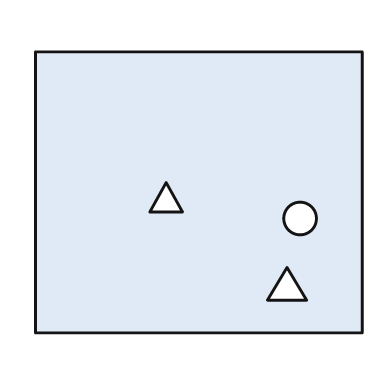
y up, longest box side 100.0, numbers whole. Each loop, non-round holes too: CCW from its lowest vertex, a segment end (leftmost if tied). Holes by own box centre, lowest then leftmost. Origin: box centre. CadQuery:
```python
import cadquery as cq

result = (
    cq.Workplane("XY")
    .moveTo(-50.0, -43.0)
    .lineTo(50.0, -43.0)
    .lineTo(50.0, 43.0)
    .lineTo(-50.0, 43.0)
    .close()
    .moveTo(21.0, -33.0)
    .lineTo(33.0, -33.0)
    .lineTo(27.0, -23.0)
    .close()
    .moveTo(31.0, -8.0)
    .circle(5.0)
    .moveTo(-15.0, -6.0)
    .lineTo(-5.0, -6.0)
    .lineTo(-10.0, 3.0)
    .close()
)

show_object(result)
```